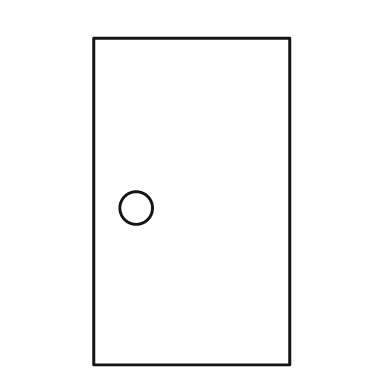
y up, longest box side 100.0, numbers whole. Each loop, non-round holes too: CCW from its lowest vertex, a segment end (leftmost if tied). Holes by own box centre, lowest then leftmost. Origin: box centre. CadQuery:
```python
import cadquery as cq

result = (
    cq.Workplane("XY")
    .moveTo(-30.0, -50.0)
    .lineTo(30.0, -50.0)
    .lineTo(30.0, 50.0)
    .lineTo(-30.0, 50.0)
    .close()
    .moveTo(-17.0, -2.0)
    .circle(5.0)
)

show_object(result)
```